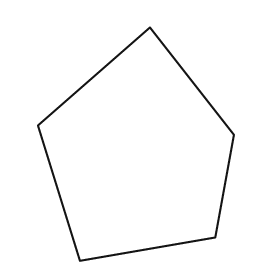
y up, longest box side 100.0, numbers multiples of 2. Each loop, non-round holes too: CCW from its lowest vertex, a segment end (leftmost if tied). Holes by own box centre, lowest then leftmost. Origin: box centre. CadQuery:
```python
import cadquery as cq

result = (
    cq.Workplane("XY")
    .moveTo(-24.0, -50.0)
    .lineTo(34.0, -40.0)
    .lineTo(42.0, 4.0)
    .lineTo(6.0, 50.0)
    .lineTo(-42.0, 8.0)
    .close()
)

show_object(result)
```